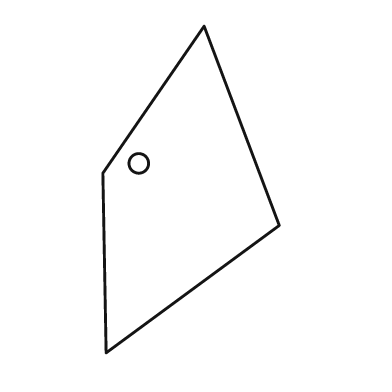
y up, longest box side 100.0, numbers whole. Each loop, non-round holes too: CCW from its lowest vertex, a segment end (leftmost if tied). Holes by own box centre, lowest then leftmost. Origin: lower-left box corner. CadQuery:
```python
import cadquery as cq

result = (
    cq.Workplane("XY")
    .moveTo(1.0, 0.0)
    .lineTo(54.0, 39.0)
    .lineTo(31.0, 100.0)
    .lineTo(0.0, 55.0)
    .close()
    .moveTo(11.0, 58.0)
    .circle(3.0)
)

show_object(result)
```